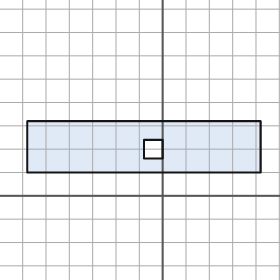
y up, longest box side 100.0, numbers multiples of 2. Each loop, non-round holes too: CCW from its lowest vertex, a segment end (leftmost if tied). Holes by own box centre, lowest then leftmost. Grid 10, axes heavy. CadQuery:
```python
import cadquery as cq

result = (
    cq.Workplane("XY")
    .moveTo(-58.0, 10.0)
    .lineTo(42.0, 10.0)
    .lineTo(42.0, 32.0)
    .lineTo(-58.0, 32.0)
    .close()
    .moveTo(-8.0, 16.0)
    .lineTo(0.0, 16.0)
    .lineTo(0.0, 24.0)
    .lineTo(-8.0, 24.0)
    .close()
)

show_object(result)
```